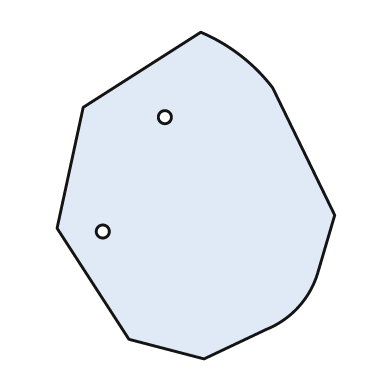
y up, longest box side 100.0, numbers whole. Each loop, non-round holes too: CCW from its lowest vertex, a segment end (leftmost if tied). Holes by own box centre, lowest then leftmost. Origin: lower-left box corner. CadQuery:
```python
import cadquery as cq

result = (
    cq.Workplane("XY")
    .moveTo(45.0, 0.0)
    .lineTo(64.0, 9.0)
    .threePointArc((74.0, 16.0), (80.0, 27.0))
    .lineTo(85.0, 44.0)
    .lineTo(66.0, 83.0)
    .threePointArc((56.0, 93.0), (44.0, 100.0))
    .lineTo(8.0, 77.0)
    .lineTo(0.0, 40.0)
    .lineTo(22.0, 6.0)
    .close()
    .moveTo(14.0, 39.0)
    .circle(2.0)
    .moveTo(33.0, 74.0)
    .circle(2.0)
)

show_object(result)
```